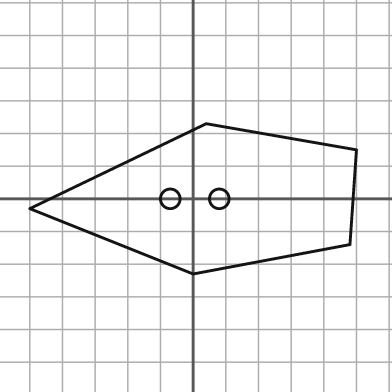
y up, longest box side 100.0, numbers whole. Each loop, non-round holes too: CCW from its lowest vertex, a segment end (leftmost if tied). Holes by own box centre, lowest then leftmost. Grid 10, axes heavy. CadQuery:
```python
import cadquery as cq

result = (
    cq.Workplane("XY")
    .moveTo(0.0, -23.0)
    .lineTo(48.0, -14.0)
    .lineTo(50.0, 15.0)
    .lineTo(4.0, 23.0)
    .lineTo(-50.0, -3.0)
    .close()
    .moveTo(-7.0, 0.0)
    .circle(3.0)
    .moveTo(8.0, 0.0)
    .circle(3.0)
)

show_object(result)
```